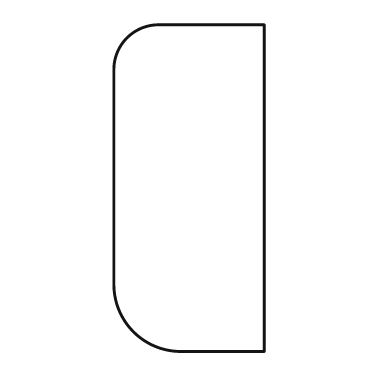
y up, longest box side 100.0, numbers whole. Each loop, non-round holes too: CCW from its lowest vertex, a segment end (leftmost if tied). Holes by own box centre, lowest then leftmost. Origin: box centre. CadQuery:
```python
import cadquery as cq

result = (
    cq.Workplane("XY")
    .moveTo(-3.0, -50.0)
    .lineTo(23.0, -50.0)
    .lineTo(23.0, 50.0)
    .lineTo(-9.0, 50.0)
    .threePointArc((-19.0, 46.0), (-23.0, 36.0))
    .lineTo(-23.0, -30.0)
    .threePointArc((-17.0, -44.0), (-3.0, -50.0))
    .close()
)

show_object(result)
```